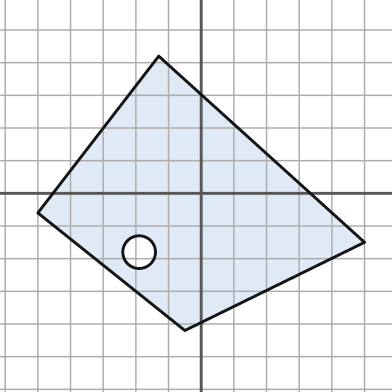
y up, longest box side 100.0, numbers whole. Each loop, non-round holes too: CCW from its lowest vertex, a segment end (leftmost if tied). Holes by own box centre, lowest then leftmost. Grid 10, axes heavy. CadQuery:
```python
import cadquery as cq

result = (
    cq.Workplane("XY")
    .moveTo(-5.0, -42.0)
    .lineTo(50.0, -15.0)
    .lineTo(-13.0, 42.0)
    .lineTo(-50.0, -6.0)
    .close()
    .moveTo(-19.0, -18.0)
    .circle(5.0)
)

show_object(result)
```